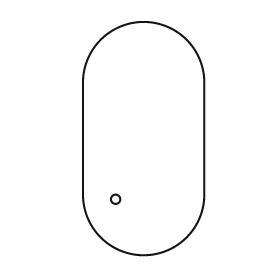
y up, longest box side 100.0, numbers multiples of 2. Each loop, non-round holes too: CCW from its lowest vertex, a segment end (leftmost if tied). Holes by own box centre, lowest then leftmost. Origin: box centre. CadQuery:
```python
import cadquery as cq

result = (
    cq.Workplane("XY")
    .moveTo(-26.0, -24.0)
    .threePointArc((0.0, -50.0), (26.0, -24.0))
    .lineTo(26.0, 24.0)
    .threePointArc((0.0, 50.0), (-26.0, 24.0))
    .close()
    .moveTo(-12.0, -26.0)
    .circle(2.0)
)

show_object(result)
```